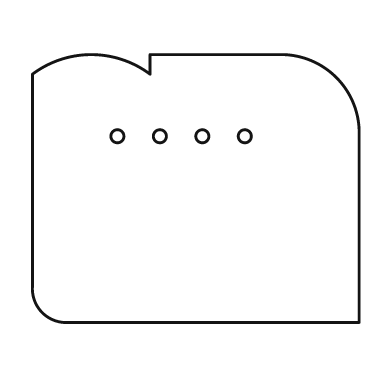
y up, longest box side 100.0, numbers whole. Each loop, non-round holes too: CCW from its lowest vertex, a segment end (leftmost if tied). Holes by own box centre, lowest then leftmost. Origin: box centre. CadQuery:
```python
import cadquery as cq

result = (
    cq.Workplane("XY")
    .moveTo(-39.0, -41.0)
    .lineTo(50.0, -41.0)
    .lineTo(50.0, 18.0)
    .threePointArc((43.0, 34.0), (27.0, 41.0))
    .lineTo(-14.0, 41.0)
    .lineTo(-14.0, 35.0)
    .threePointArc((-32.0, 41.0), (-50.0, 35.0))
    .lineTo(-50.0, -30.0)
    .threePointArc((-47.0, -38.0), (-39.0, -41.0))
    .close()
    .moveTo(-24.0, 16.0)
    .circle(2.0)
    .moveTo(-11.0, 16.0)
    .circle(2.0)
    .moveTo(2.0, 16.0)
    .circle(2.0)
    .moveTo(15.0, 16.0)
    .circle(2.0)
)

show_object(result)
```